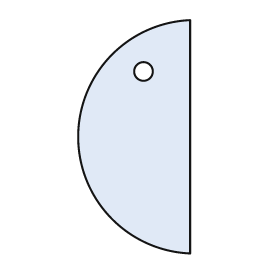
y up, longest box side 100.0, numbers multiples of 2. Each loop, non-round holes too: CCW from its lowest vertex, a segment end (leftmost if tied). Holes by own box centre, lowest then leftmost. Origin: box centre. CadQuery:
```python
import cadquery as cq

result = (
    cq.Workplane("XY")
    .moveTo(24.0, -50.0)
    .lineTo(24.0, 50.0)
    .threePointArc((-24.0, 0.0), (24.0, -50.0))
    .close()
    .moveTo(4.0, 28.0)
    .circle(4.0)
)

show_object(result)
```